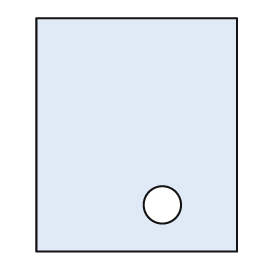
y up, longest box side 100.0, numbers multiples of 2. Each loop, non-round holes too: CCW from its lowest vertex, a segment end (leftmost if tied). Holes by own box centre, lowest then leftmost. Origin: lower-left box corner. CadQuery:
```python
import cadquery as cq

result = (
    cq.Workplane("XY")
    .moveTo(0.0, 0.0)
    .lineTo(86.0, 0.0)
    .lineTo(86.0, 100.0)
    .lineTo(0.0, 100.0)
    .close()
    .moveTo(54.0, 20.0)
    .circle(8.0)
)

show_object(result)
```